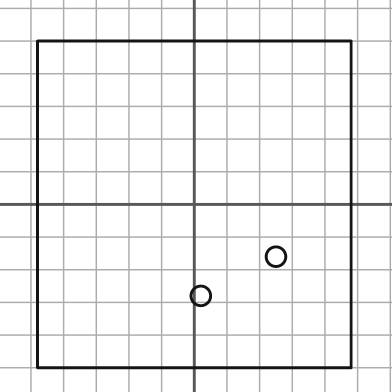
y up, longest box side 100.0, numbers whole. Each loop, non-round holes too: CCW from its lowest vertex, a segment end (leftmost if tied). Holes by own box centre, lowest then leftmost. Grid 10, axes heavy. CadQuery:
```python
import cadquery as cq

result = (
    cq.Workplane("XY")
    .moveTo(-48.0, -50.0)
    .lineTo(48.0, -50.0)
    .lineTo(48.0, 50.0)
    .lineTo(-48.0, 50.0)
    .close()
    .moveTo(2.0, -28.0)
    .circle(3.0)
    .moveTo(25.0, -16.0)
    .circle(3.0)
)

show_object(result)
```